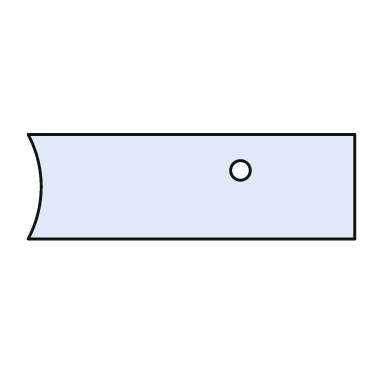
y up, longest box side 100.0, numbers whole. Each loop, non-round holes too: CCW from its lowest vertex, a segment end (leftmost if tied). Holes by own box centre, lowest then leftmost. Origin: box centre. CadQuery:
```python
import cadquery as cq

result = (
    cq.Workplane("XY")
    .moveTo(-50.0, -16.0)
    .lineTo(50.0, -16.0)
    .lineTo(50.0, 16.0)
    .lineTo(-50.0, 16.0)
    .threePointArc((-46.0, 0.0), (-50.0, -16.0))
    .close()
    .moveTo(15.0, 5.0)
    .circle(3.0)
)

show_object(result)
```